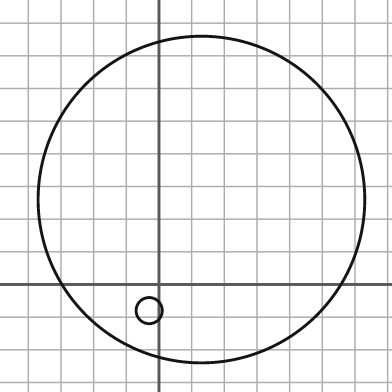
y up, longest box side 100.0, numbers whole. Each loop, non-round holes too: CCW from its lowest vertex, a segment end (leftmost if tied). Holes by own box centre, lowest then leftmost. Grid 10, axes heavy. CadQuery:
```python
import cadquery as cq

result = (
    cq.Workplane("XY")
    .moveTo(13.0, 26.0)
    .circle(50.0)
    .moveTo(-3.0, -8.0)
    .circle(4.0)
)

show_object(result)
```